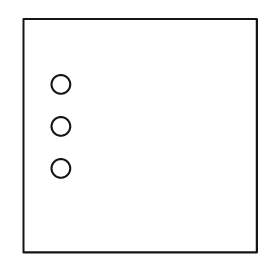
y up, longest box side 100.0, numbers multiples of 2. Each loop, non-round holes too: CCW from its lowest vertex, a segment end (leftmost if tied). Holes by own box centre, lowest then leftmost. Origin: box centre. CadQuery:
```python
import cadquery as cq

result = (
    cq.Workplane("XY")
    .moveTo(-50.0, -50.0)
    .lineTo(50.0, -50.0)
    .lineTo(50.0, 50.0)
    .lineTo(-50.0, 50.0)
    .close()
    .moveTo(-34.0, -14.0)
    .circle(4.0)
    .moveTo(-34.0, 4.0)
    .circle(4.0)
    .moveTo(-34.0, 22.0)
    .circle(4.0)
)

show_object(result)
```